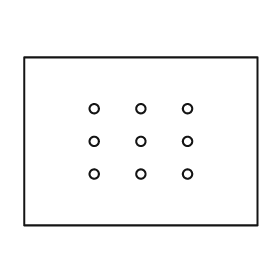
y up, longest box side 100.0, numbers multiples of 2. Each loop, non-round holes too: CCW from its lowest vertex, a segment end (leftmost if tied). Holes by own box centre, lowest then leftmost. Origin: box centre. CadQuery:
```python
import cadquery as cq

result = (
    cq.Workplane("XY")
    .moveTo(-50.0, -36.0)
    .lineTo(50.0, -36.0)
    .lineTo(50.0, 36.0)
    .lineTo(-50.0, 36.0)
    .close()
    .moveTo(-20.0, -14.0)
    .circle(2.0)
    .moveTo(0.0, -14.0)
    .circle(2.0)
    .moveTo(20.0, -14.0)
    .circle(2.0)
    .moveTo(-20.0, 0.0)
    .circle(2.0)
    .moveTo(0.0, 0.0)
    .circle(2.0)
    .moveTo(20.0, 0.0)
    .circle(2.0)
    .moveTo(-20.0, 14.0)
    .circle(2.0)
    .moveTo(0.0, 14.0)
    .circle(2.0)
    .moveTo(20.0, 14.0)
    .circle(2.0)
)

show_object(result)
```